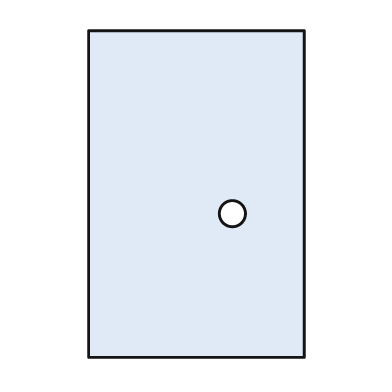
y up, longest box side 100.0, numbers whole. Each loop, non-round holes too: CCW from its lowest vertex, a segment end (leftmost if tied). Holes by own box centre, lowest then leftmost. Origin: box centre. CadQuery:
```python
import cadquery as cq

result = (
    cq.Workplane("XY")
    .moveTo(-33.0, -50.0)
    .lineTo(33.0, -50.0)
    .lineTo(33.0, 50.0)
    .lineTo(-33.0, 50.0)
    .close()
    .moveTo(11.0, -6.0)
    .circle(4.0)
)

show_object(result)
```